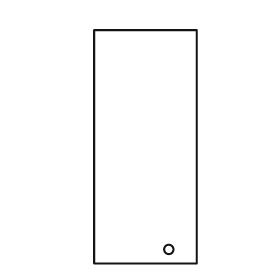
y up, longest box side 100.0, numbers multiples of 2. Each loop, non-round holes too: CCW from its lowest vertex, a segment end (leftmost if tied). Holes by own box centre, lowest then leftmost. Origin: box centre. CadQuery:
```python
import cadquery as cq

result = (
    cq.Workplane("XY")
    .moveTo(-22.0, -50.0)
    .lineTo(22.0, -50.0)
    .lineTo(22.0, 50.0)
    .lineTo(-22.0, 50.0)
    .close()
    .moveTo(10.0, -44.0)
    .circle(2.0)
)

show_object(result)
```